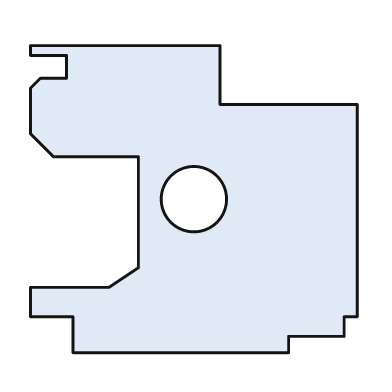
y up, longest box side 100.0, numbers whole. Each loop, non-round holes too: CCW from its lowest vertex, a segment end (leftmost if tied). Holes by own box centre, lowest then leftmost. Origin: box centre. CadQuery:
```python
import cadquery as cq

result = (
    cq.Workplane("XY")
    .moveTo(-37.0, -47.0)
    .lineTo(29.0, -47.0)
    .lineTo(29.0, -42.0)
    .lineTo(46.0, -42.0)
    .lineTo(46.0, -36.0)
    .lineTo(50.0, -36.0)
    .lineTo(50.0, 29.0)
    .lineTo(8.0, 29.0)
    .lineTo(8.0, 47.0)
    .lineTo(-50.0, 47.0)
    .lineTo(-50.0, 44.0)
    .lineTo(-39.0, 44.0)
    .lineTo(-39.0, 37.0)
    .lineTo(-47.0, 37.0)
    .lineTo(-50.0, 34.0)
    .lineTo(-50.0, 20.0)
    .lineTo(-43.0, 13.0)
    .lineTo(-17.0, 13.0)
    .lineTo(-17.0, -21.0)
    .lineTo(-26.0, -27.0)
    .lineTo(-50.0, -27.0)
    .lineTo(-50.0, -36.0)
    .lineTo(-37.0, -36.0)
    .close()
    .moveTo(0.0, 0.0)
    .circle(10.0)
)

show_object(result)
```